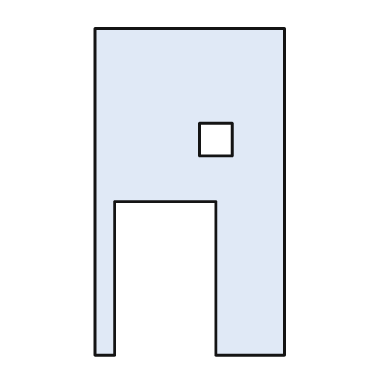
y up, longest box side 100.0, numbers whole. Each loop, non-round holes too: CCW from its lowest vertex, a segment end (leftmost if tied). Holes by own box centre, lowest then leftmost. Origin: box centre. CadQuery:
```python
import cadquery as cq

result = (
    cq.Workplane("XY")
    .moveTo(-29.0, -50.0)
    .lineTo(-23.0, -50.0)
    .lineTo(-23.0, -3.0)
    .lineTo(8.0, -3.0)
    .lineTo(8.0, -50.0)
    .lineTo(29.0, -50.0)
    .lineTo(29.0, 50.0)
    .lineTo(-29.0, 50.0)
    .close()
    .moveTo(3.0, 11.0)
    .lineTo(13.0, 11.0)
    .lineTo(13.0, 21.0)
    .lineTo(3.0, 21.0)
    .close()
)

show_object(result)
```